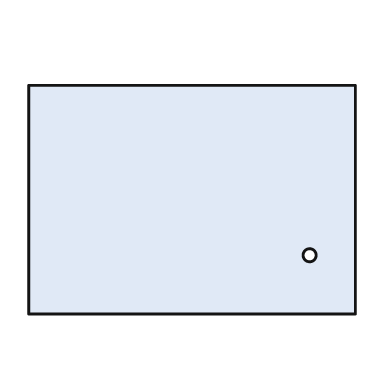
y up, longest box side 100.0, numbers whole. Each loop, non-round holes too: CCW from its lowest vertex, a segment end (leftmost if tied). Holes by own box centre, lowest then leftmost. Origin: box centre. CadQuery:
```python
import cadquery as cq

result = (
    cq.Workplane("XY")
    .moveTo(-50.0, -35.0)
    .lineTo(50.0, -35.0)
    .lineTo(50.0, 35.0)
    .lineTo(-50.0, 35.0)
    .close()
    .moveTo(36.0, -17.0)
    .circle(2.0)
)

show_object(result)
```